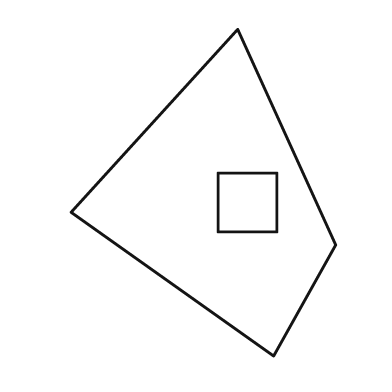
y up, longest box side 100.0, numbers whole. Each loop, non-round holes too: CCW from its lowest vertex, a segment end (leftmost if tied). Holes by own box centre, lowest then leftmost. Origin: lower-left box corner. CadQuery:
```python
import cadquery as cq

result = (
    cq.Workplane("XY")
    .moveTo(62.0, 0.0)
    .lineTo(81.0, 34.0)
    .lineTo(51.0, 100.0)
    .lineTo(0.0, 44.0)
    .close()
    .moveTo(45.0, 38.0)
    .lineTo(63.0, 38.0)
    .lineTo(63.0, 56.0)
    .lineTo(45.0, 56.0)
    .close()
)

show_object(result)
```